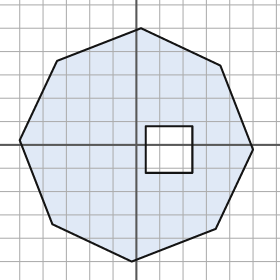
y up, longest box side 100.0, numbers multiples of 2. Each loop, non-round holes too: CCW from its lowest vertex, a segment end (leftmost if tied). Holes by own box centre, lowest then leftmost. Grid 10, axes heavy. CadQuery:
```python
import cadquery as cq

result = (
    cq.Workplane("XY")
    .moveTo(-2.0, -50.0)
    .lineTo(34.0, -36.0)
    .lineTo(50.0, -2.0)
    .lineTo(36.0, 34.0)
    .lineTo(2.0, 50.0)
    .lineTo(-34.0, 36.0)
    .lineTo(-50.0, 2.0)
    .lineTo(-36.0, -34.0)
    .close()
    .moveTo(4.0, -12.0)
    .lineTo(24.0, -12.0)
    .lineTo(24.0, 8.0)
    .lineTo(4.0, 8.0)
    .close()
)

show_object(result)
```